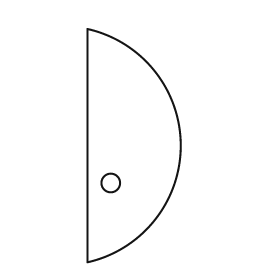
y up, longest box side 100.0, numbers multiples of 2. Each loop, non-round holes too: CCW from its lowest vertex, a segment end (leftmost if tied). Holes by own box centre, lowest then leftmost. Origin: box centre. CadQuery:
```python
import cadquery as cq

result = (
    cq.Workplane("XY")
    .moveTo(-20.0, -50.0)
    .threePointArc((20.0, 0.0), (-20.0, 50.0))
    .close()
    .moveTo(-10.0, -16.0)
    .circle(4.0)
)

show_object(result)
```